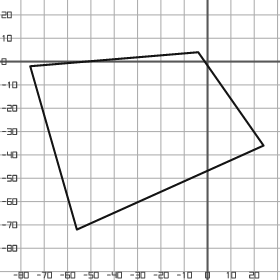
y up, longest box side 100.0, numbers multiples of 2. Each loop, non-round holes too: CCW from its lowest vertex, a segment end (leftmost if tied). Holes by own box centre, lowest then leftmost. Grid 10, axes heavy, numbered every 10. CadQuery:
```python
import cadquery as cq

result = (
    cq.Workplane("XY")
    .moveTo(-56.0, -72.0)
    .lineTo(24.0, -36.0)
    .lineTo(-4.0, 4.0)
    .lineTo(-76.0, -2.0)
    .close()
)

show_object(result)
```